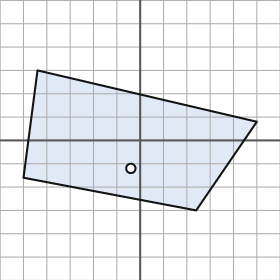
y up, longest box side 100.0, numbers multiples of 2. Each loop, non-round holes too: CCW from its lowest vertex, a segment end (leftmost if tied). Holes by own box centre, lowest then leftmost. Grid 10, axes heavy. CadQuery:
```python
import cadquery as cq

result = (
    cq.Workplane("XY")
    .moveTo(24.0, -30.0)
    .lineTo(50.0, 8.0)
    .lineTo(-44.0, 30.0)
    .lineTo(-50.0, -16.0)
    .close()
    .moveTo(-4.0, -12.0)
    .circle(2.0)
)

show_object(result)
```